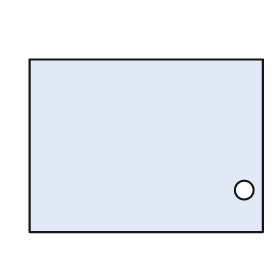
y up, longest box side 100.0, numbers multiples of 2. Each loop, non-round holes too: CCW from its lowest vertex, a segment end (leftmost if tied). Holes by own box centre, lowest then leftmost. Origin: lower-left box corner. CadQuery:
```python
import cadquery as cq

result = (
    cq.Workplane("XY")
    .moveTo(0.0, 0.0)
    .lineTo(100.0, 0.0)
    .lineTo(100.0, 74.0)
    .lineTo(0.0, 74.0)
    .close()
    .moveTo(92.0, 18.0)
    .circle(4.0)
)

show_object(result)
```